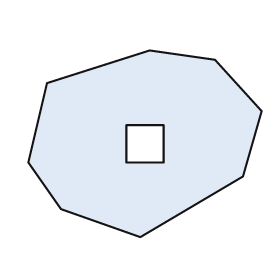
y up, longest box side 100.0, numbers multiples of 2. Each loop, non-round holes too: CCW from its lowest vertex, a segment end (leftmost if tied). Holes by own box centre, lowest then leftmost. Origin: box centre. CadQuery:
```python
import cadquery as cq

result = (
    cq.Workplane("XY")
    .moveTo(-2.0, -40.0)
    .lineTo(42.0, -14.0)
    .lineTo(50.0, 14.0)
    .lineTo(30.0, 36.0)
    .lineTo(2.0, 40.0)
    .lineTo(-42.0, 26.0)
    .lineTo(-50.0, -8.0)
    .lineTo(-36.0, -28.0)
    .close()
    .moveTo(-8.0, -8.0)
    .lineTo(8.0, -8.0)
    .lineTo(8.0, 8.0)
    .lineTo(-8.0, 8.0)
    .close()
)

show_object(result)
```